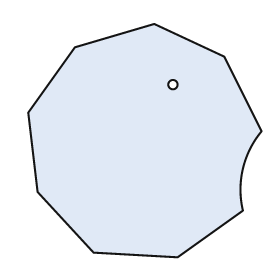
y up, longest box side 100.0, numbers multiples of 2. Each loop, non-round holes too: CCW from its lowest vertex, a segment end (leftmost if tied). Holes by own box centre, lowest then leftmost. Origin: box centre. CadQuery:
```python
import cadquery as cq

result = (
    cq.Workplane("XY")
    .moveTo(14.0, -50.0)
    .lineTo(42.0, -30.0)
    .threePointArc((42.0, -12.0), (50.0, 4.0))
    .lineTo(34.0, 36.0)
    .lineTo(4.0, 50.0)
    .lineTo(-30.0, 40.0)
    .lineTo(-50.0, 12.0)
    .lineTo(-46.0, -22.0)
    .lineTo(-22.0, -48.0)
    .close()
    .moveTo(12.0, 24.0)
    .circle(2.0)
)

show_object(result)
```